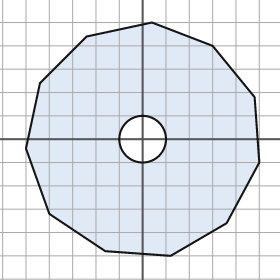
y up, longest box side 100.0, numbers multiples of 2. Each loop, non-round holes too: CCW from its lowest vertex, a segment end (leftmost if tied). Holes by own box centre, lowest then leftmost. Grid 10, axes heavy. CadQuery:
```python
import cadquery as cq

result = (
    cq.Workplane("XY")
    .moveTo(12.0, -50.0)
    .lineTo(36.0, -36.0)
    .lineTo(50.0, -10.0)
    .lineTo(48.0, 18.0)
    .lineTo(30.0, 40.0)
    .lineTo(4.0, 50.0)
    .lineTo(-24.0, 44.0)
    .lineTo(-44.0, 24.0)
    .lineTo(-50.0, -4.0)
    .lineTo(-40.0, -32.0)
    .lineTo(-16.0, -48.0)
    .close()
    .moveTo(0.0, 0.0)
    .circle(10.0)
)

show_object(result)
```